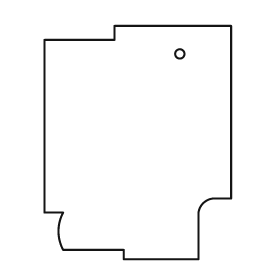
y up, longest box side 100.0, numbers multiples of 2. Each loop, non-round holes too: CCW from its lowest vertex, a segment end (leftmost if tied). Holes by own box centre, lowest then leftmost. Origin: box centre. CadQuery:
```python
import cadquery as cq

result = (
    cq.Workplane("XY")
    .moveTo(-6.0, -50.0)
    .lineTo(26.0, -50.0)
    .lineTo(26.0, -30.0)
    .threePointArc((28.0, -26.0), (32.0, -24.0))
    .lineTo(40.0, -24.0)
    .lineTo(40.0, 50.0)
    .lineTo(-10.0, 50.0)
    .lineTo(-10.0, 44.0)
    .lineTo(-40.0, 44.0)
    .lineTo(-40.0, -30.0)
    .lineTo(-32.0, -30.0)
    .threePointArc((-34.0, -38.0), (-32.0, -46.0))
    .lineTo(-6.0, -46.0)
    .close()
    .moveTo(18.0, 38.0)
    .circle(2.0)
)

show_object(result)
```